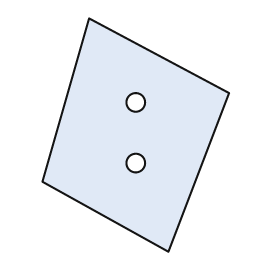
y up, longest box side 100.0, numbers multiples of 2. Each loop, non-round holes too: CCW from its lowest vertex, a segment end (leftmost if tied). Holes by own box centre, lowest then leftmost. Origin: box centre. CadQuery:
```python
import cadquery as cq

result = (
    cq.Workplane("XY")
    .moveTo(14.0, -50.0)
    .lineTo(40.0, 18.0)
    .lineTo(-20.0, 50.0)
    .lineTo(-40.0, -20.0)
    .close()
    .moveTo(0.0, -12.0)
    .circle(4.0)
    .moveTo(0.0, 14.0)
    .circle(4.0)
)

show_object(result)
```